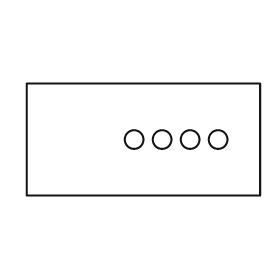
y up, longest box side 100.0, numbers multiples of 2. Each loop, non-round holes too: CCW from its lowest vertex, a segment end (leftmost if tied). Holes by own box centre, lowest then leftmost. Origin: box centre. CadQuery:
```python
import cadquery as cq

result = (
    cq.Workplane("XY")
    .moveTo(-50.0, -24.0)
    .lineTo(50.0, -24.0)
    .lineTo(50.0, 24.0)
    .lineTo(-50.0, 24.0)
    .close()
    .moveTo(-4.0, 0.0)
    .circle(4.0)
    .moveTo(8.0, 0.0)
    .circle(4.0)
    .moveTo(20.0, 0.0)
    .circle(4.0)
    .moveTo(32.0, 0.0)
    .circle(4.0)
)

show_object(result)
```